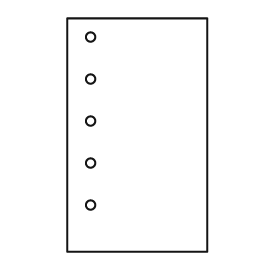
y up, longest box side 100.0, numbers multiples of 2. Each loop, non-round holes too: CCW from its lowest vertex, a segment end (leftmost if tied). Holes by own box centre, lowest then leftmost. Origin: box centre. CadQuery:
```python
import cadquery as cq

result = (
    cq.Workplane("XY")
    .moveTo(-30.0, -50.0)
    .lineTo(30.0, -50.0)
    .lineTo(30.0, 50.0)
    .lineTo(-30.0, 50.0)
    .close()
    .moveTo(-20.0, -30.0)
    .circle(2.0)
    .moveTo(-20.0, -12.0)
    .circle(2.0)
    .moveTo(-20.0, 6.0)
    .circle(2.0)
    .moveTo(-20.0, 24.0)
    .circle(2.0)
    .moveTo(-20.0, 42.0)
    .circle(2.0)
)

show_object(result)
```